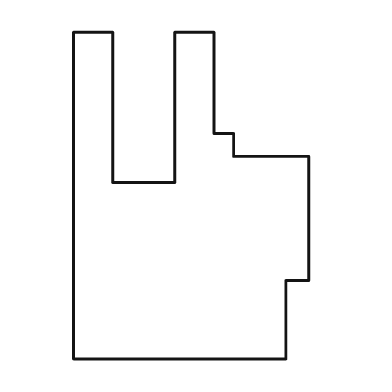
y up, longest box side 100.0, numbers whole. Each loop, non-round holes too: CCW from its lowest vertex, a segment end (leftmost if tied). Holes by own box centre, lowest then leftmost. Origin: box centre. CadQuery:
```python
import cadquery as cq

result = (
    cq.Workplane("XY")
    .moveTo(-36.0, -50.0)
    .lineTo(29.0, -50.0)
    .lineTo(29.0, -26.0)
    .lineTo(36.0, -26.0)
    .lineTo(36.0, 12.0)
    .lineTo(13.0, 12.0)
    .lineTo(13.0, 19.0)
    .lineTo(7.0, 19.0)
    .lineTo(7.0, 50.0)
    .lineTo(-5.0, 50.0)
    .lineTo(-5.0, 4.0)
    .lineTo(-24.0, 4.0)
    .lineTo(-24.0, 50.0)
    .lineTo(-36.0, 50.0)
    .close()
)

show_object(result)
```